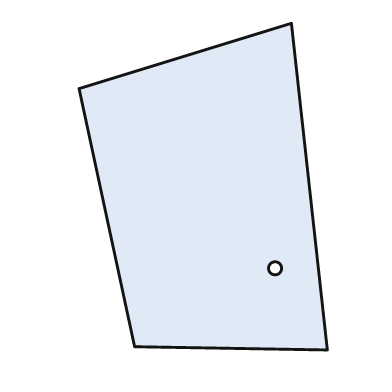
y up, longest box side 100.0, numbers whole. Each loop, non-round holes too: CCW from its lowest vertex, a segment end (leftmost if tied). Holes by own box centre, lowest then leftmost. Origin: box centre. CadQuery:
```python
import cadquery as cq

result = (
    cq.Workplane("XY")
    .moveTo(38.0, -50.0)
    .lineTo(27.0, 50.0)
    .lineTo(-38.0, 30.0)
    .lineTo(-21.0, -49.0)
    .close()
    .moveTo(22.0, -25.0)
    .circle(2.0)
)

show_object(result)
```